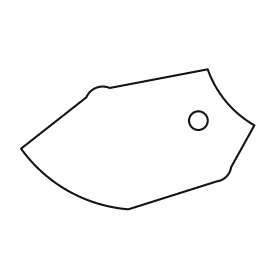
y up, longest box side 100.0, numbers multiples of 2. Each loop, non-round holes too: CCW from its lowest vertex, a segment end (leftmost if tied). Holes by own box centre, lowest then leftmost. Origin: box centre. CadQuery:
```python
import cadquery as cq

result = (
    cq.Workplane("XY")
    .moveTo(-4.0, -30.0)
    .lineTo(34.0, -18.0)
    .threePointArc((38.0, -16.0), (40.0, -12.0))
    .lineTo(50.0, 6.0)
    .threePointArc((38.0, 16.0), (30.0, 30.0))
    .lineTo(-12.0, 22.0)
    .threePointArc((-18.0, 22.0), (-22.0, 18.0))
    .lineTo(-50.0, -4.0)
    .threePointArc((-30.0, -22.0), (-4.0, -30.0))
    .close()
    .moveTo(26.0, 8.0)
    .circle(4.0)
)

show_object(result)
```